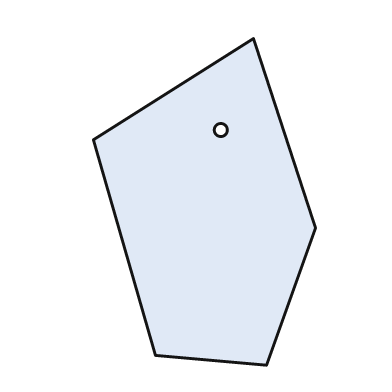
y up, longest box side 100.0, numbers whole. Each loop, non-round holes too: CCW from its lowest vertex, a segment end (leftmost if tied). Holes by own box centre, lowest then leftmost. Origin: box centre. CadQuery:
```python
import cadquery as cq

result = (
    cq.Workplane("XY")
    .moveTo(19.0, -50.0)
    .lineTo(34.0, -8.0)
    .lineTo(15.0, 50.0)
    .lineTo(-34.0, 19.0)
    .lineTo(-15.0, -47.0)
    .close()
    .moveTo(5.0, 22.0)
    .circle(2.0)
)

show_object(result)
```